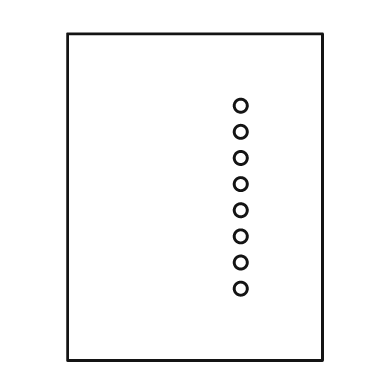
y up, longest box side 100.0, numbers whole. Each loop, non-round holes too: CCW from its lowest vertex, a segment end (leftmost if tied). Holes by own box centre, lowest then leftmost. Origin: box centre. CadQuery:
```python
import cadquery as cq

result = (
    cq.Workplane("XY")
    .moveTo(-39.0, -50.0)
    .lineTo(39.0, -50.0)
    .lineTo(39.0, 50.0)
    .lineTo(-39.0, 50.0)
    .close()
    .moveTo(14.0, -28.0)
    .circle(2.0)
    .moveTo(14.0, -20.0)
    .circle(2.0)
    .moveTo(14.0, -12.0)
    .circle(2.0)
    .moveTo(14.0, -4.0)
    .circle(2.0)
    .moveTo(14.0, 4.0)
    .circle(2.0)
    .moveTo(14.0, 12.0)
    .circle(2.0)
    .moveTo(14.0, 20.0)
    .circle(2.0)
    .moveTo(14.0, 28.0)
    .circle(2.0)
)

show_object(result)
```